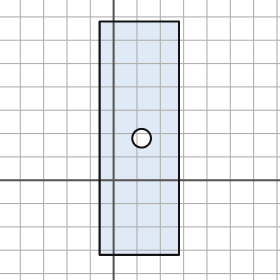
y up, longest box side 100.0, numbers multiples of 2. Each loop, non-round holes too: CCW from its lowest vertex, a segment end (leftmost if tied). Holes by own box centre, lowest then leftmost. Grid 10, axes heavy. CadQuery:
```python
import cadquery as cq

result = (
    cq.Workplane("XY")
    .moveTo(-6.0, -32.0)
    .lineTo(28.0, -32.0)
    .lineTo(28.0, 68.0)
    .lineTo(-6.0, 68.0)
    .close()
    .moveTo(12.0, 18.0)
    .circle(4.0)
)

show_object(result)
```